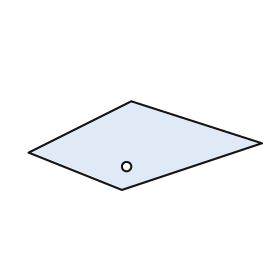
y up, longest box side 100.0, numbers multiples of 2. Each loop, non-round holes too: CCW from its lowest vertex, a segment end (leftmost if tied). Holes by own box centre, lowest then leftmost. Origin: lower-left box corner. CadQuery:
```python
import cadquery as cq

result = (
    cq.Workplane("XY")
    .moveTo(40.0, 0.0)
    .lineTo(100.0, 20.0)
    .lineTo(44.0, 38.0)
    .lineTo(0.0, 16.0)
    .close()
    .moveTo(42.0, 10.0)
    .circle(2.0)
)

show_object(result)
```